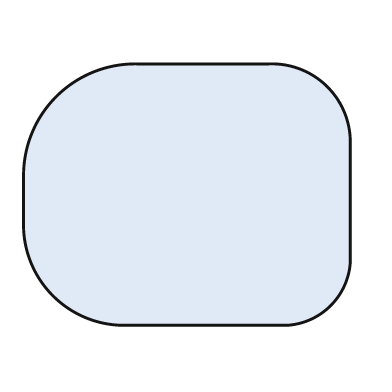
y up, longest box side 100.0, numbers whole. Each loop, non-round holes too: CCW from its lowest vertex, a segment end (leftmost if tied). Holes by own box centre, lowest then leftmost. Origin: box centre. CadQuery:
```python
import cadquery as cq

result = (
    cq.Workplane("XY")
    .moveTo(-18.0, -40.0)
    .lineTo(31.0, -40.0)
    .threePointArc((44.0, -34.0), (50.0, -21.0))
    .lineTo(50.0, 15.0)
    .threePointArc((43.0, 33.0), (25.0, 40.0))
    .lineTo(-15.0, 40.0)
    .threePointArc((-40.0, 30.0), (-50.0, 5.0))
    .lineTo(-50.0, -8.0)
    .threePointArc((-41.0, -31.0), (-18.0, -40.0))
    .close()
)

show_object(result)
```